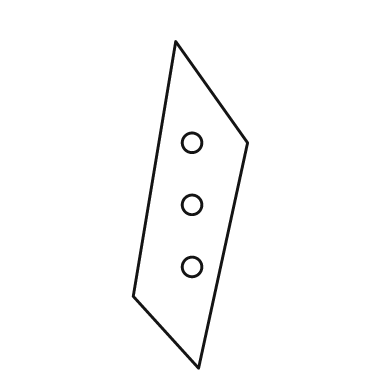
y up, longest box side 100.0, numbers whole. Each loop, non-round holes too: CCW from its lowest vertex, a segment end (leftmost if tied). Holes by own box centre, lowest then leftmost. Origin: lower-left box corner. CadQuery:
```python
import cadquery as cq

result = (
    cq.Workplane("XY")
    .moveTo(20.0, 0.0)
    .lineTo(35.0, 69.0)
    .lineTo(13.0, 100.0)
    .lineTo(0.0, 22.0)
    .close()
    .moveTo(18.0, 31.0)
    .circle(3.0)
    .moveTo(18.0, 50.0)
    .circle(3.0)
    .moveTo(18.0, 69.0)
    .circle(3.0)
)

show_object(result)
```